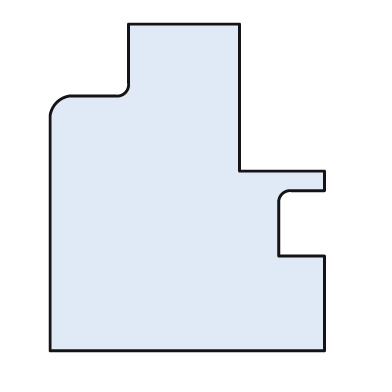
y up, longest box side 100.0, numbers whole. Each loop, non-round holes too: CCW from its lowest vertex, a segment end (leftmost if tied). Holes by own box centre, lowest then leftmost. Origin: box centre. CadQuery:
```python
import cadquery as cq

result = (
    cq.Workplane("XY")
    .moveTo(-42.0, -50.0)
    .lineTo(42.0, -50.0)
    .lineTo(42.0, -21.0)
    .lineTo(28.0, -21.0)
    .lineTo(28.0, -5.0)
    .threePointArc((29.0, -2.0), (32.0, -1.0))
    .lineTo(42.0, -1.0)
    .lineTo(42.0, 5.0)
    .lineTo(16.0, 5.0)
    .lineTo(16.0, 50.0)
    .lineTo(-18.0, 50.0)
    .lineTo(-18.0, 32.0)
    .threePointArc((-19.0, 29.0), (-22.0, 28.0))
    .lineTo(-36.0, 28.0)
    .threePointArc((-40.0, 26.0), (-42.0, 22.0))
    .close()
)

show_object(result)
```